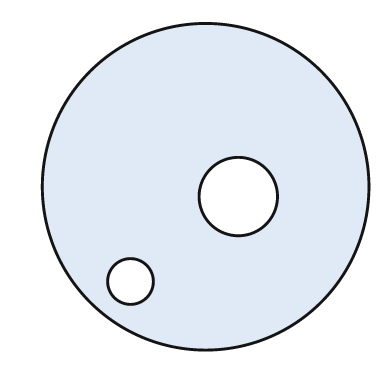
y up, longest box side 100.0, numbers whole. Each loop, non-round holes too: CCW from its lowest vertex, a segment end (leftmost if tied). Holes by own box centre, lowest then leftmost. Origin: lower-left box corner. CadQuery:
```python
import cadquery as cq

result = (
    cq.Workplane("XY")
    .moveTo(50.0, 50.0)
    .circle(50.0)
    .moveTo(27.0, 21.0)
    .circle(7.0)
    .moveTo(60.0, 47.0)
    .circle(12.0)
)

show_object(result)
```